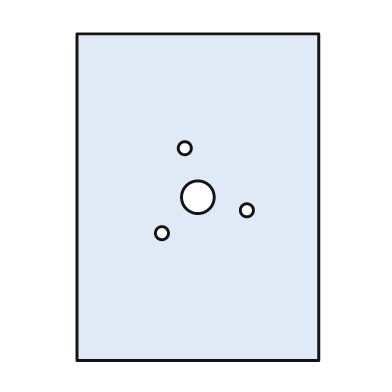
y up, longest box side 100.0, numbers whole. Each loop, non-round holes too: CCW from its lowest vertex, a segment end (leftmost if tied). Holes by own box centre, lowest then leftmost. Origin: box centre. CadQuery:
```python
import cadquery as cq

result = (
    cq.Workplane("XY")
    .moveTo(-37.0, -50.0)
    .lineTo(37.0, -50.0)
    .lineTo(37.0, 50.0)
    .lineTo(-37.0, 50.0)
    .close()
    .moveTo(-11.0, -11.0)
    .circle(2.0)
    .moveTo(15.0, -4.0)
    .circle(2.0)
    .moveTo(0.0, 0.0)
    .circle(5.0)
    .moveTo(-4.0, 15.0)
    .circle(2.0)
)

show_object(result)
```